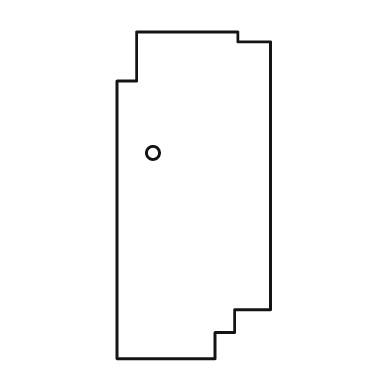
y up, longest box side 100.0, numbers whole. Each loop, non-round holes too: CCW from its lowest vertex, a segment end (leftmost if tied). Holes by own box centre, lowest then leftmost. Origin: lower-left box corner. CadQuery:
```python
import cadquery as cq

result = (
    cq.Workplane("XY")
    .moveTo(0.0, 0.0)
    .lineTo(30.0, 0.0)
    .lineTo(30.0, 8.0)
    .lineTo(36.0, 8.0)
    .lineTo(36.0, 15.0)
    .lineTo(47.0, 15.0)
    .lineTo(47.0, 97.0)
    .lineTo(37.0, 97.0)
    .lineTo(37.0, 100.0)
    .lineTo(6.0, 100.0)
    .lineTo(6.0, 85.0)
    .lineTo(0.0, 85.0)
    .close()
    .moveTo(11.0, 63.0)
    .circle(2.0)
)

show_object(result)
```